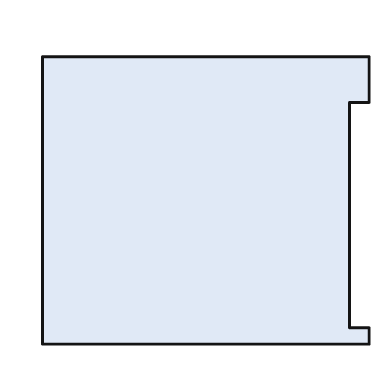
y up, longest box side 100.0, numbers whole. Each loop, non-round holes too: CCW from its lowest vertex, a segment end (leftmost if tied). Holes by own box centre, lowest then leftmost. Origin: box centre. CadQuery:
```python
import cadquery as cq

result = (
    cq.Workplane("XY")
    .moveTo(-50.0, -44.0)
    .lineTo(50.0, -44.0)
    .lineTo(50.0, -39.0)
    .lineTo(44.0, -39.0)
    .lineTo(44.0, 30.0)
    .lineTo(50.0, 30.0)
    .lineTo(50.0, 44.0)
    .lineTo(-50.0, 44.0)
    .close()
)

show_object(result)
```